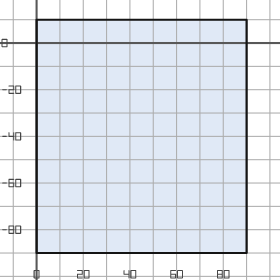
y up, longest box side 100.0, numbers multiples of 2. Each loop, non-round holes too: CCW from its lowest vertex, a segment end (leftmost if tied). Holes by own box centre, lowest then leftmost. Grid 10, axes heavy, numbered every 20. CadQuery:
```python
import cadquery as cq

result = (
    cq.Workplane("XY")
    .moveTo(0.0, -90.0)
    .lineTo(90.0, -90.0)
    .lineTo(90.0, 10.0)
    .lineTo(0.0, 10.0)
    .close()
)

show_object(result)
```